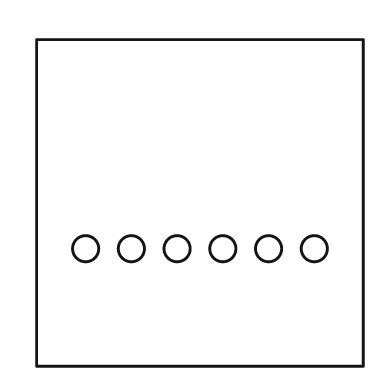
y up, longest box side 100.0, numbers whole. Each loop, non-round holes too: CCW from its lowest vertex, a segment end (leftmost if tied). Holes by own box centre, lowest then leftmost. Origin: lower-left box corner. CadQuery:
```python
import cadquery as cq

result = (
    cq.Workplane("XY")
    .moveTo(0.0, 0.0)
    .lineTo(100.0, 0.0)
    .lineTo(100.0, 100.0)
    .lineTo(0.0, 100.0)
    .close()
    .moveTo(15.0, 36.0)
    .circle(4.0)
    .moveTo(29.0, 36.0)
    .circle(4.0)
    .moveTo(43.0, 36.0)
    .circle(4.0)
    .moveTo(57.0, 36.0)
    .circle(4.0)
    .moveTo(71.0, 36.0)
    .circle(4.0)
    .moveTo(85.0, 36.0)
    .circle(4.0)
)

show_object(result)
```